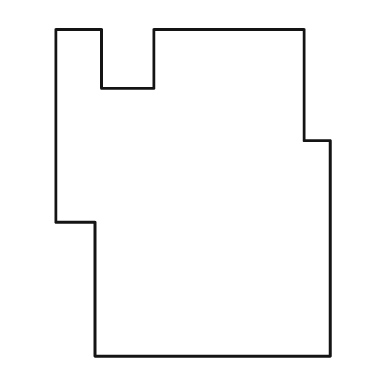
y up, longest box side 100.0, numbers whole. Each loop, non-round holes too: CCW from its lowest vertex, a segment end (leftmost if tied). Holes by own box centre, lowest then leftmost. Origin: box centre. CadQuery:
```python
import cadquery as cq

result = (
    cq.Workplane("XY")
    .moveTo(-30.0, -50.0)
    .lineTo(42.0, -50.0)
    .lineTo(42.0, 16.0)
    .lineTo(34.0, 16.0)
    .lineTo(34.0, 50.0)
    .lineTo(-12.0, 50.0)
    .lineTo(-12.0, 32.0)
    .lineTo(-28.0, 32.0)
    .lineTo(-28.0, 50.0)
    .lineTo(-42.0, 50.0)
    .lineTo(-42.0, -9.0)
    .lineTo(-30.0, -9.0)
    .close()
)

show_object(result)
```